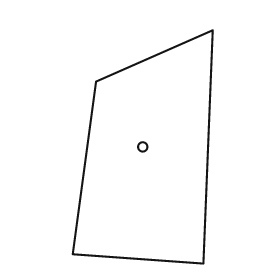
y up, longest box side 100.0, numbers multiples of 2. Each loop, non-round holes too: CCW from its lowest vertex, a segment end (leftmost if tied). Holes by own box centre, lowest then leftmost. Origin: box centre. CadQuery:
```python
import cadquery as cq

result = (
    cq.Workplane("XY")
    .moveTo(26.0, -50.0)
    .lineTo(30.0, 50.0)
    .lineTo(-20.0, 28.0)
    .lineTo(-30.0, -46.0)
    .close()
    .moveTo(0.0, 0.0)
    .circle(2.0)
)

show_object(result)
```